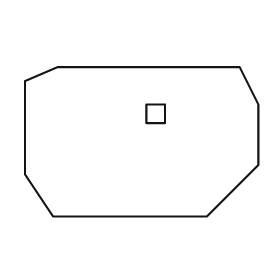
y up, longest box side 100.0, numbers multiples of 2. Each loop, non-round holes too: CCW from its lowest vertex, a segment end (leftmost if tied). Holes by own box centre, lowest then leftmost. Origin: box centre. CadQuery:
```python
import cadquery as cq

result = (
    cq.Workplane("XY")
    .moveTo(-38.0, -32.0)
    .lineTo(28.0, -32.0)
    .lineTo(50.0, -10.0)
    .lineTo(50.0, 16.0)
    .lineTo(42.0, 32.0)
    .lineTo(-36.0, 32.0)
    .lineTo(-50.0, 26.0)
    .lineTo(-50.0, -14.0)
    .close()
    .moveTo(2.0, 8.0)
    .lineTo(10.0, 8.0)
    .lineTo(10.0, 16.0)
    .lineTo(2.0, 16.0)
    .close()
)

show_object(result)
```